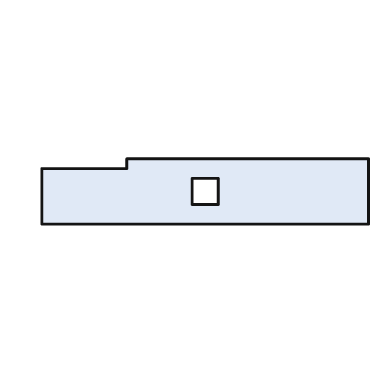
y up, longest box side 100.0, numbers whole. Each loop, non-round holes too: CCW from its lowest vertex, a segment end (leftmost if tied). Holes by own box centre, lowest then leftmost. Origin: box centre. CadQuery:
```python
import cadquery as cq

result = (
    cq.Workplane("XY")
    .moveTo(-50.0, -10.0)
    .lineTo(50.0, -10.0)
    .lineTo(50.0, 10.0)
    .lineTo(-24.0, 10.0)
    .lineTo(-24.0, 7.0)
    .lineTo(-50.0, 7.0)
    .close()
    .moveTo(-4.0, -4.0)
    .lineTo(4.0, -4.0)
    .lineTo(4.0, 4.0)
    .lineTo(-4.0, 4.0)
    .close()
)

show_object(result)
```